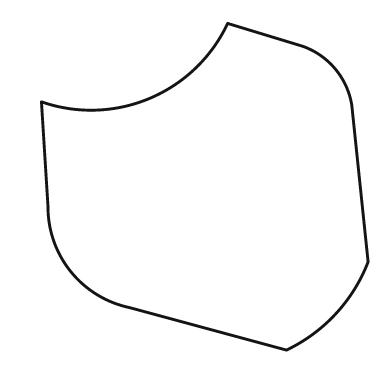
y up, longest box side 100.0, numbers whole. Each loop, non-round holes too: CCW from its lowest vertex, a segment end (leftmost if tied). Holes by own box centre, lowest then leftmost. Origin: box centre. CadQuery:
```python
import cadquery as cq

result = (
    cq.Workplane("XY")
    .moveTo(25.0, -50.0)
    .threePointArc((40.0, -39.0), (50.0, -23.0))
    .lineTo(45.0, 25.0)
    .threePointArc((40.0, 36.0), (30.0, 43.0))
    .lineTo(7.0, 50.0)
    .threePointArc((-17.0, 27.0), (-50.0, 26.0))
    .lineTo(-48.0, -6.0)
    .threePointArc((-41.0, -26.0), (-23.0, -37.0))
    .close()
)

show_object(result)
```